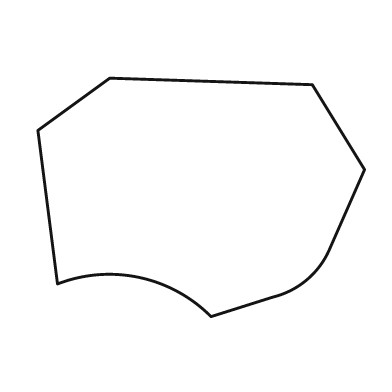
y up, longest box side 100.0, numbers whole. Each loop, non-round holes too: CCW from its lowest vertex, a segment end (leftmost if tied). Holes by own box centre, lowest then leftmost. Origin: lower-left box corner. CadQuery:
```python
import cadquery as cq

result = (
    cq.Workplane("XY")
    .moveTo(53.0, 0.0)
    .lineTo(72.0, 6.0)
    .threePointArc((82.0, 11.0), (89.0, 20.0))
    .lineTo(100.0, 45.0)
    .lineTo(84.0, 71.0)
    .lineTo(22.0, 73.0)
    .lineTo(0.0, 57.0)
    .lineTo(6.0, 10.0)
    .threePointArc((31.0, 12.0), (53.0, 0.0))
    .close()
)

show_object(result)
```